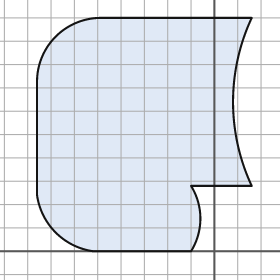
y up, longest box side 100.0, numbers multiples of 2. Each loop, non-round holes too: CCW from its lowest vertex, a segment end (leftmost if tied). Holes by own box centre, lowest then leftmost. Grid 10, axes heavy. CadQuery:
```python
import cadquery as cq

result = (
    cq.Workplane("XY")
    .moveTo(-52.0, 0.0)
    .lineTo(-10.0, 0.0)
    .threePointArc((-6.0, 14.0), (-10.0, 28.0))
    .lineTo(16.0, 28.0)
    .threePointArc((8.0, 64.0), (16.0, 100.0))
    .lineTo(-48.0, 100.0)
    .threePointArc((-68.0, 92.0), (-76.0, 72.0))
    .lineTo(-76.0, 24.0)
    .threePointArc((-68.0, 8.0), (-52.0, 0.0))
    .close()
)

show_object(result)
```